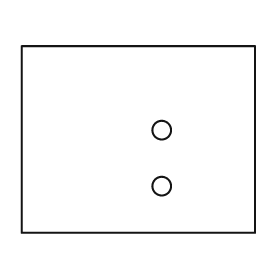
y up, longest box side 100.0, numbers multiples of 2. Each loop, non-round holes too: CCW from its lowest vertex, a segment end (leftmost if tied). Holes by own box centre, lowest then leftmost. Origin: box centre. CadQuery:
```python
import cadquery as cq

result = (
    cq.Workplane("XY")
    .moveTo(-50.0, -40.0)
    .lineTo(50.0, -40.0)
    .lineTo(50.0, 40.0)
    .lineTo(-50.0, 40.0)
    .close()
    .moveTo(10.0, -20.0)
    .circle(4.0)
    .moveTo(10.0, 4.0)
    .circle(4.0)
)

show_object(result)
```